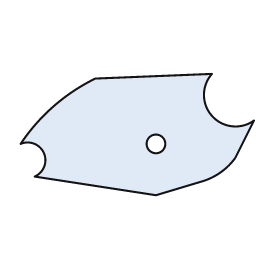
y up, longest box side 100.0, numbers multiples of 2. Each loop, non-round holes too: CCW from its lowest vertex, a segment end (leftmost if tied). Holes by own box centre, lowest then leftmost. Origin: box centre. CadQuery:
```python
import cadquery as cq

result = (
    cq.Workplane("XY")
    .moveTo(8.0, -26.0)
    .lineTo(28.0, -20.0)
    .threePointArc((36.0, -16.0), (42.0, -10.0))
    .lineTo(50.0, 6.0)
    .threePointArc((32.0, 8.0), (32.0, 26.0))
    .lineTo(-18.0, 24.0)
    .threePointArc((-36.0, 12.0), (-50.0, -4.0))
    .threePointArc((-40.0, -8.0), (-44.0, -18.0))
    .close()
    .moveTo(8.0, -4.0)
    .circle(4.0)
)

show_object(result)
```